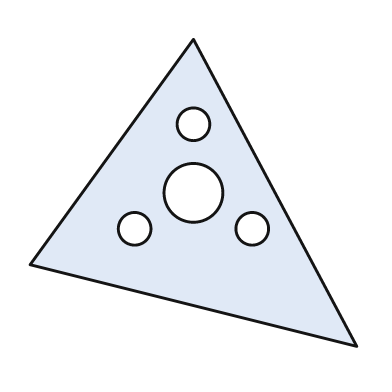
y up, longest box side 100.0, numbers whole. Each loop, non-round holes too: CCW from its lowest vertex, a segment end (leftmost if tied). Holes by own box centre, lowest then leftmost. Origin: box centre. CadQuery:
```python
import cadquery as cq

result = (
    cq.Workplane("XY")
    .moveTo(50.0, -47.0)
    .lineTo(0.0, 47.0)
    .lineTo(-50.0, -22.0)
    .close()
    .moveTo(-18.0, -11.0)
    .circle(5.0)
    .moveTo(18.0, -11.0)
    .circle(5.0)
    .moveTo(0.0, 0.0)
    .circle(9.0)
    .moveTo(0.0, 21.0)
    .circle(5.0)
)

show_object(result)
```